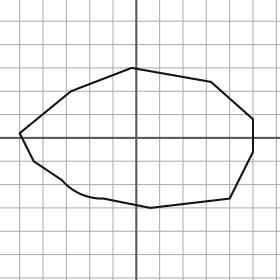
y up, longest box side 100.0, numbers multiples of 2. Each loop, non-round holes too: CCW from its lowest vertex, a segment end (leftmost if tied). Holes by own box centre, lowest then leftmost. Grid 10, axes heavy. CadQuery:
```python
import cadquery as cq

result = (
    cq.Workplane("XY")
    .moveTo(6.0, -30.0)
    .lineTo(40.0, -26.0)
    .lineTo(50.0, -6.0)
    .lineTo(50.0, 8.0)
    .lineTo(32.0, 24.0)
    .lineTo(-2.0, 30.0)
    .lineTo(-28.0, 20.0)
    .lineTo(-50.0, 2.0)
    .lineTo(-44.0, -10.0)
    .lineTo(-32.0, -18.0)
    .threePointArc((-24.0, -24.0), (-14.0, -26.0))
    .close()
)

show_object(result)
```